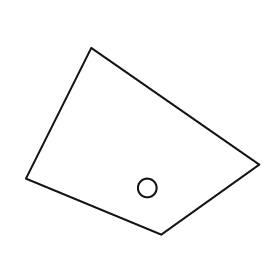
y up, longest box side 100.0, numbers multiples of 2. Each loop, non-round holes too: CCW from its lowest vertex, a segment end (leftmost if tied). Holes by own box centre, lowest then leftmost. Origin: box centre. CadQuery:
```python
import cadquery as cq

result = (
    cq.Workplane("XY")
    .moveTo(8.0, -40.0)
    .lineTo(50.0, -10.0)
    .lineTo(-22.0, 40.0)
    .lineTo(-50.0, -16.0)
    .close()
    .moveTo(2.0, -20.0)
    .circle(4.0)
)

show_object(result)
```